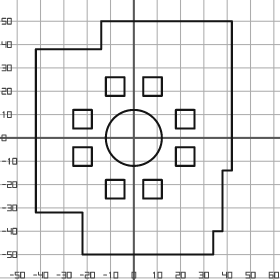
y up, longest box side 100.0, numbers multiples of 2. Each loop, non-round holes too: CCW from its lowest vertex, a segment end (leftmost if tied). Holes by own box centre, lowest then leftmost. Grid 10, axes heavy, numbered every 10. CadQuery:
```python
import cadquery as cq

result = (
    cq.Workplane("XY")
    .moveTo(-22.0, -50.0)
    .lineTo(34.0, -50.0)
    .lineTo(34.0, -40.0)
    .lineTo(38.0, -40.0)
    .lineTo(38.0, -14.0)
    .lineTo(42.0, -14.0)
    .lineTo(42.0, 50.0)
    .lineTo(-14.0, 50.0)
    .lineTo(-14.0, 38.0)
    .lineTo(-42.0, 38.0)
    .lineTo(-42.0, -32.0)
    .lineTo(-22.0, -32.0)
    .close()
    .moveTo(-12.0, -26.0)
    .lineTo(-4.0, -26.0)
    .lineTo(-4.0, -18.0)
    .lineTo(-12.0, -18.0)
    .close()
    .moveTo(4.0, -26.0)
    .lineTo(12.0, -26.0)
    .lineTo(12.0, -18.0)
    .lineTo(4.0, -18.0)
    .close()
    .moveTo(-26.0, -12.0)
    .lineTo(-18.0, -12.0)
    .lineTo(-18.0, -4.0)
    .lineTo(-26.0, -4.0)
    .close()
    .moveTo(18.0, -12.0)
    .lineTo(26.0, -12.0)
    .lineTo(26.0, -4.0)
    .lineTo(18.0, -4.0)
    .close()
    .moveTo(0.0, 0.0)
    .circle(12.0)
    .moveTo(-26.0, 4.0)
    .lineTo(-18.0, 4.0)
    .lineTo(-18.0, 12.0)
    .lineTo(-26.0, 12.0)
    .close()
    .moveTo(18.0, 4.0)
    .lineTo(26.0, 4.0)
    .lineTo(26.0, 12.0)
    .lineTo(18.0, 12.0)
    .close()
    .moveTo(-12.0, 18.0)
    .lineTo(-4.0, 18.0)
    .lineTo(-4.0, 26.0)
    .lineTo(-12.0, 26.0)
    .close()
    .moveTo(4.0, 18.0)
    .lineTo(12.0, 18.0)
    .lineTo(12.0, 26.0)
    .lineTo(4.0, 26.0)
    .close()
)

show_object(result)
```